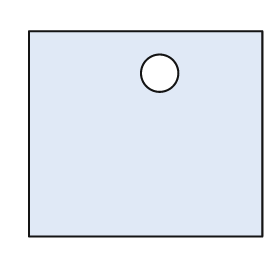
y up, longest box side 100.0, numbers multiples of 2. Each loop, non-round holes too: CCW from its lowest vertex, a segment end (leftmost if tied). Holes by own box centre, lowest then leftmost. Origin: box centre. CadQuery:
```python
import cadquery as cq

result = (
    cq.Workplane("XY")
    .moveTo(-50.0, -44.0)
    .lineTo(50.0, -44.0)
    .lineTo(50.0, 44.0)
    .lineTo(-50.0, 44.0)
    .close()
    .moveTo(6.0, 26.0)
    .circle(8.0)
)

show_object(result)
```